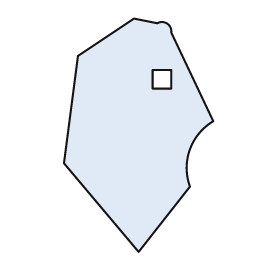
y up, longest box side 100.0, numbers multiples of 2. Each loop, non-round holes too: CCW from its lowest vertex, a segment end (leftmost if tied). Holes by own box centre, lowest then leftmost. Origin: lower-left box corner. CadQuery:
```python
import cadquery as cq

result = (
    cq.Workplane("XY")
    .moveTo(32.0, 0.0)
    .lineTo(54.0, 28.0)
    .threePointArc((54.0, 44.0), (64.0, 56.0))
    .lineTo(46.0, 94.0)
    .threePointArc((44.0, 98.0), (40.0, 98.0))
    .lineTo(30.0, 100.0)
    .lineTo(6.0, 84.0)
    .lineTo(0.0, 38.0)
    .close()
    .moveTo(38.0, 70.0)
    .lineTo(46.0, 70.0)
    .lineTo(46.0, 78.0)
    .lineTo(38.0, 78.0)
    .close()
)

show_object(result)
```